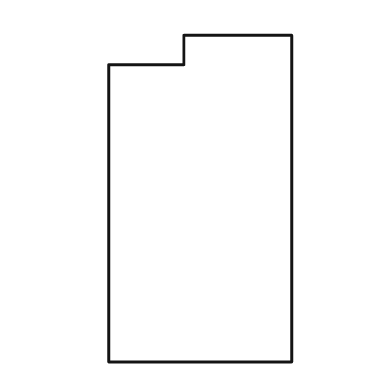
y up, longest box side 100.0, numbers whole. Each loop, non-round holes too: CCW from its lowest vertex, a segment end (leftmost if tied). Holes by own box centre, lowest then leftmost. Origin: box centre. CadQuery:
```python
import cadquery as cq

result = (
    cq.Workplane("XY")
    .moveTo(-28.0, -50.0)
    .lineTo(28.0, -50.0)
    .lineTo(28.0, 50.0)
    .lineTo(-5.0, 50.0)
    .lineTo(-5.0, 41.0)
    .lineTo(-28.0, 41.0)
    .close()
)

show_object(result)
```